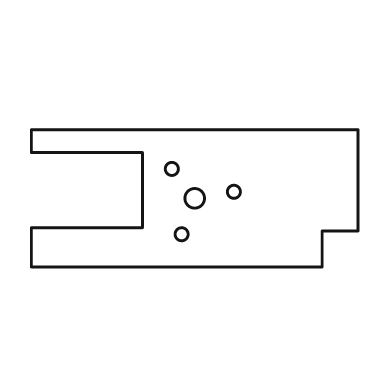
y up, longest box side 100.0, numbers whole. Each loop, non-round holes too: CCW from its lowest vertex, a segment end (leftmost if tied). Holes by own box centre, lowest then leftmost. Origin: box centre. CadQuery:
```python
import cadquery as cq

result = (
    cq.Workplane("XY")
    .moveTo(-50.0, -21.0)
    .lineTo(39.0, -21.0)
    .lineTo(39.0, -10.0)
    .lineTo(50.0, -10.0)
    .lineTo(50.0, 21.0)
    .lineTo(-50.0, 21.0)
    .lineTo(-50.0, 14.0)
    .lineTo(-16.0, 14.0)
    .lineTo(-16.0, -9.0)
    .lineTo(-50.0, -9.0)
    .close()
    .moveTo(-4.0, -11.0)
    .circle(2.0)
    .moveTo(0.0, 0.0)
    .circle(3.0)
    .moveTo(12.0, 2.0)
    .circle(2.0)
    .moveTo(-7.0, 9.0)
    .circle(2.0)
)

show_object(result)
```